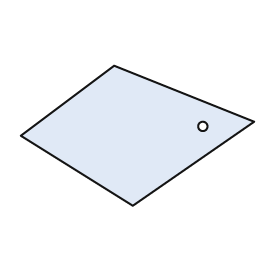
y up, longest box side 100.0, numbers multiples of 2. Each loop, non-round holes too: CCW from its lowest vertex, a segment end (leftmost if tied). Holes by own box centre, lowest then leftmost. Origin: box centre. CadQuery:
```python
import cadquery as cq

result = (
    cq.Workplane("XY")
    .moveTo(-2.0, -30.0)
    .lineTo(50.0, 6.0)
    .lineTo(-10.0, 30.0)
    .lineTo(-50.0, 0.0)
    .close()
    .moveTo(28.0, 4.0)
    .circle(2.0)
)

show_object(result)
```